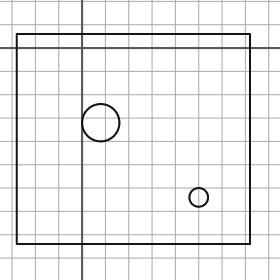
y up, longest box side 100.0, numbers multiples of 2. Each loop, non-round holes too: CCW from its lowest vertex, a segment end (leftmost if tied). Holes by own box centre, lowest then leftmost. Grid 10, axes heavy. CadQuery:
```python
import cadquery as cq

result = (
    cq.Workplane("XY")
    .moveTo(-28.0, -84.0)
    .lineTo(72.0, -84.0)
    .lineTo(72.0, 6.0)
    .lineTo(-28.0, 6.0)
    .close()
    .moveTo(50.0, -64.0)
    .circle(4.0)
    .moveTo(8.0, -32.0)
    .circle(8.0)
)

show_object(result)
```